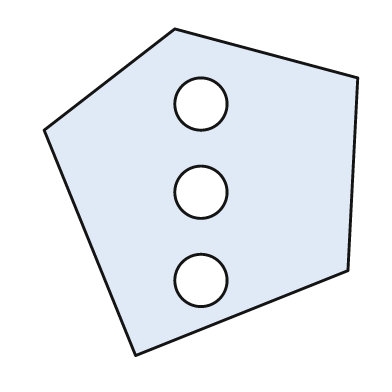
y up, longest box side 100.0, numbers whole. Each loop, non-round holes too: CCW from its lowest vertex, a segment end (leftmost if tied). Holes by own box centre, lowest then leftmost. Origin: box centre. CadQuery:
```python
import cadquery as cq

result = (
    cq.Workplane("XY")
    .moveTo(-20.0, -50.0)
    .lineTo(45.0, -24.0)
    .lineTo(48.0, 35.0)
    .lineTo(-8.0, 50.0)
    .lineTo(-48.0, 19.0)
    .close()
    .moveTo(0.0, -27.0)
    .circle(8.0)
    .moveTo(0.0, 0.0)
    .circle(8.0)
    .moveTo(0.0, 27.0)
    .circle(8.0)
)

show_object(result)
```